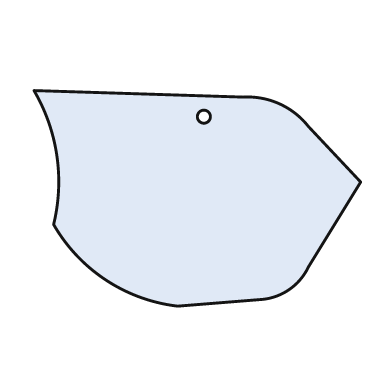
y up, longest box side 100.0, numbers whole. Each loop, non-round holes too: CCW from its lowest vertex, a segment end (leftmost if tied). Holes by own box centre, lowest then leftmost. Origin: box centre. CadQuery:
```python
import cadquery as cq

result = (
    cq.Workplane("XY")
    .moveTo(-6.0, -33.0)
    .lineTo(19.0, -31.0)
    .threePointArc((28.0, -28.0), (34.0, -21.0))
    .lineTo(50.0, 5.0)
    .lineTo(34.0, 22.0)
    .threePointArc((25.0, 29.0), (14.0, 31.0))
    .lineTo(-50.0, 33.0)
    .threePointArc((-43.0, 13.0), (-44.0, -8.0))
    .threePointArc((-28.0, -25.0), (-6.0, -33.0))
    .close()
    .moveTo(2.0, 25.0)
    .circle(2.0)
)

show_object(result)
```